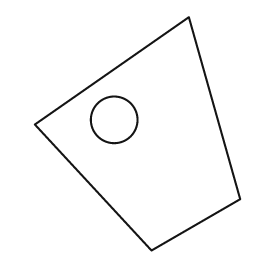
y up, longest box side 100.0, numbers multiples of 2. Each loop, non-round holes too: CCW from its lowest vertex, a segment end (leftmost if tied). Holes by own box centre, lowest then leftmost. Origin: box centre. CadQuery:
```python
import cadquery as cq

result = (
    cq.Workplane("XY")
    .moveTo(6.0, -50.0)
    .lineTo(44.0, -28.0)
    .lineTo(22.0, 50.0)
    .lineTo(-44.0, 4.0)
    .close()
    .moveTo(-10.0, 6.0)
    .circle(10.0)
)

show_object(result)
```